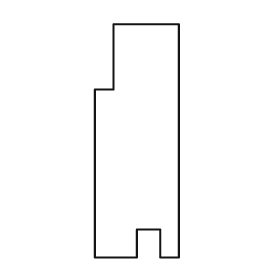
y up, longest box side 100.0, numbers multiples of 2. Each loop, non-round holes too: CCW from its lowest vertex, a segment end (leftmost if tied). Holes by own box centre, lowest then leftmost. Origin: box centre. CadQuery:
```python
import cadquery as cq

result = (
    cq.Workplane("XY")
    .moveTo(-18.0, -50.0)
    .lineTo(0.0, -50.0)
    .lineTo(0.0, -38.0)
    .lineTo(10.0, -38.0)
    .lineTo(10.0, -50.0)
    .lineTo(18.0, -50.0)
    .lineTo(18.0, 50.0)
    .lineTo(-10.0, 50.0)
    .lineTo(-10.0, 22.0)
    .lineTo(-18.0, 22.0)
    .close()
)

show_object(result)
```